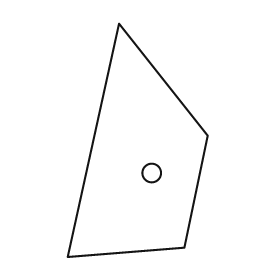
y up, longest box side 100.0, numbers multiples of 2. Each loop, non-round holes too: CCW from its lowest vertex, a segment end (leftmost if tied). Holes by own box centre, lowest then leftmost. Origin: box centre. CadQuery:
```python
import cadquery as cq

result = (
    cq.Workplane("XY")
    .moveTo(-30.0, -50.0)
    .lineTo(20.0, -46.0)
    .lineTo(30.0, 2.0)
    .lineTo(-8.0, 50.0)
    .close()
    .moveTo(6.0, -14.0)
    .circle(4.0)
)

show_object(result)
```